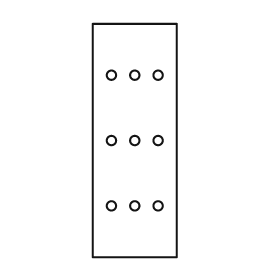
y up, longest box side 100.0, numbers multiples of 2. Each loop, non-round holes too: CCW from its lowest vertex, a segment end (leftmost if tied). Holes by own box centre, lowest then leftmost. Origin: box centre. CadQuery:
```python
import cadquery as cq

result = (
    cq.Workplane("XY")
    .moveTo(-18.0, -50.0)
    .lineTo(18.0, -50.0)
    .lineTo(18.0, 50.0)
    .lineTo(-18.0, 50.0)
    .close()
    .moveTo(-10.0, -28.0)
    .circle(2.0)
    .moveTo(0.0, -28.0)
    .circle(2.0)
    .moveTo(10.0, -28.0)
    .circle(2.0)
    .moveTo(-10.0, 0.0)
    .circle(2.0)
    .moveTo(0.0, 0.0)
    .circle(2.0)
    .moveTo(10.0, 0.0)
    .circle(2.0)
    .moveTo(-10.0, 28.0)
    .circle(2.0)
    .moveTo(0.0, 28.0)
    .circle(2.0)
    .moveTo(10.0, 28.0)
    .circle(2.0)
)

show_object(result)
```